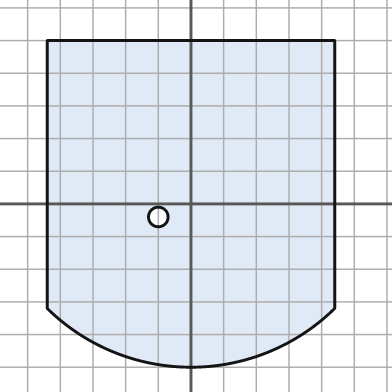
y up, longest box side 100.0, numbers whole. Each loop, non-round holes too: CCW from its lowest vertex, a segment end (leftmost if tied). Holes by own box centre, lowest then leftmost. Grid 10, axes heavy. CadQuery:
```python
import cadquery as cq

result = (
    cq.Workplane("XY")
    .moveTo(-44.0, -32.0)
    .threePointArc((0.0, -50.0), (44.0, -32.0))
    .lineTo(44.0, 50.0)
    .lineTo(-44.0, 50.0)
    .close()
    .moveTo(-10.0, -4.0)
    .circle(3.0)
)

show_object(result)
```